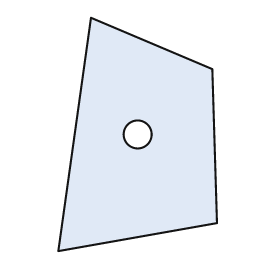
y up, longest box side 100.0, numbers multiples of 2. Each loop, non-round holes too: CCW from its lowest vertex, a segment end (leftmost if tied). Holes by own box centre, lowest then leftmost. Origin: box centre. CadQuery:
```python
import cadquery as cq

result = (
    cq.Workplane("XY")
    .moveTo(-34.0, -50.0)
    .lineTo(34.0, -38.0)
    .lineTo(32.0, 28.0)
    .lineTo(-20.0, 50.0)
    .close()
    .moveTo(0.0, 0.0)
    .circle(6.0)
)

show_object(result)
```